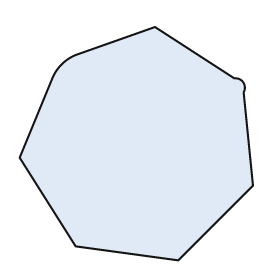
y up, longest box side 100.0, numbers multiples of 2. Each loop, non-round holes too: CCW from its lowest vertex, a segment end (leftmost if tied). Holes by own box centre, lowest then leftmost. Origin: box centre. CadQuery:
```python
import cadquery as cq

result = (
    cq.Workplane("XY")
    .moveTo(18.0, -50.0)
    .lineTo(50.0, -18.0)
    .lineTo(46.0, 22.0)
    .threePointArc((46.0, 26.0), (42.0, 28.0))
    .lineTo(8.0, 50.0)
    .lineTo(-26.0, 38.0)
    .threePointArc((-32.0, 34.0), (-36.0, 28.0))
    .lineTo(-50.0, -6.0)
    .lineTo(-26.0, -44.0)
    .close()
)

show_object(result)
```